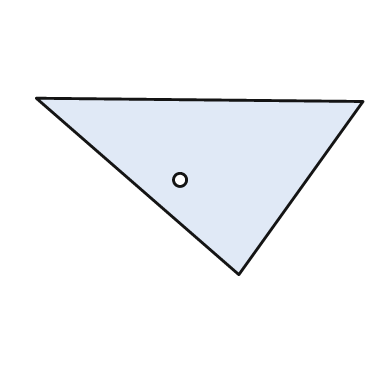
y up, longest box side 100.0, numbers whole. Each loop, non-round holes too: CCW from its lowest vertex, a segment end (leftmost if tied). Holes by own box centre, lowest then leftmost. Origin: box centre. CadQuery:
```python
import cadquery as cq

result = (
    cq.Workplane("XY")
    .moveTo(12.0, -27.0)
    .lineTo(50.0, 26.0)
    .lineTo(-50.0, 27.0)
    .close()
    .moveTo(-6.0, 2.0)
    .circle(2.0)
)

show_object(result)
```